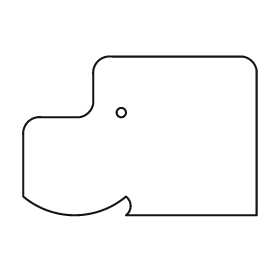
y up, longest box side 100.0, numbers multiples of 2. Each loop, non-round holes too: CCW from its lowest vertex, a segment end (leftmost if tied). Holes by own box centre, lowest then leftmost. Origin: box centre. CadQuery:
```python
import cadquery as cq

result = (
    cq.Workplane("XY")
    .moveTo(-6.0, -34.0)
    .lineTo(50.0, -34.0)
    .lineTo(50.0, 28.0)
    .threePointArc((48.0, 32.0), (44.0, 34.0))
    .lineTo(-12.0, 34.0)
    .threePointArc((-18.0, 32.0), (-20.0, 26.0))
    .lineTo(-20.0, 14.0)
    .threePointArc((-22.0, 10.0), (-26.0, 8.0))
    .lineTo(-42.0, 8.0)
    .threePointArc((-48.0, 6.0), (-50.0, 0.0))
    .lineTo(-50.0, -26.0)
    .threePointArc((-28.0, -34.0), (-6.0, -26.0))
    .threePointArc((-4.0, -30.0), (-6.0, -34.0))
    .close()
    .moveTo(-8.0, 10.0)
    .circle(2.0)
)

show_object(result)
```